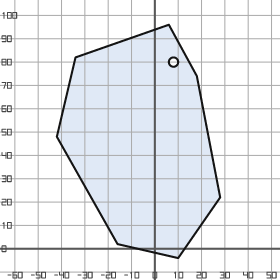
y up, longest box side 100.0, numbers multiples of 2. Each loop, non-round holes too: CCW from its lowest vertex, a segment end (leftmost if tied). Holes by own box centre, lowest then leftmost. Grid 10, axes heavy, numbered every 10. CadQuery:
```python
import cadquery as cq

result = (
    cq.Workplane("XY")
    .moveTo(10.0, -4.0)
    .lineTo(28.0, 22.0)
    .lineTo(18.0, 74.0)
    .lineTo(6.0, 96.0)
    .lineTo(-34.0, 82.0)
    .lineTo(-42.0, 48.0)
    .lineTo(-16.0, 2.0)
    .close()
    .moveTo(8.0, 80.0)
    .circle(2.0)
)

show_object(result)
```